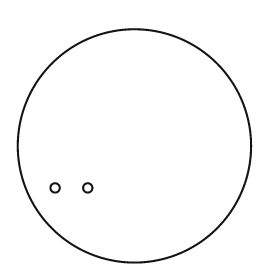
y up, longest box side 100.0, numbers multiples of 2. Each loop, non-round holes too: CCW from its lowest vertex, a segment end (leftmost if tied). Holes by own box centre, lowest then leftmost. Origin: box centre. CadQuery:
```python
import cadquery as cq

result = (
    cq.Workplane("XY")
    .moveTo(0.0, 0.0)
    .circle(50.0)
    .moveTo(-34.0, -18.0)
    .circle(2.0)
    .moveTo(-20.0, -18.0)
    .circle(2.0)
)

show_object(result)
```